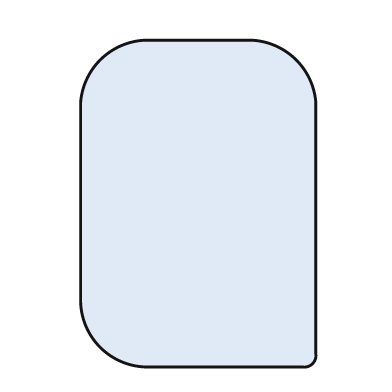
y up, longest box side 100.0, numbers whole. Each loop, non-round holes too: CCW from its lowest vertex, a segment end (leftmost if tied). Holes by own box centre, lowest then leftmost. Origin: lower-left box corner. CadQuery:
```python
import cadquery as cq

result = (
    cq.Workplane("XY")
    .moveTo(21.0, 0.0)
    .lineTo(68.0, 0.0)
    .threePointArc((71.0, 1.0), (72.0, 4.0))
    .lineTo(72.0, 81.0)
    .threePointArc((66.0, 94.0), (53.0, 100.0))
    .lineTo(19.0, 100.0)
    .threePointArc((6.0, 94.0), (0.0, 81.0))
    .lineTo(0.0, 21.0)
    .threePointArc((6.0, 6.0), (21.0, 0.0))
    .close()
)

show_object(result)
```